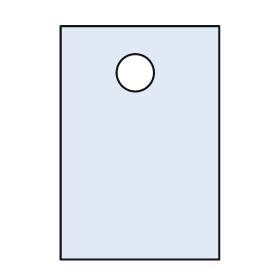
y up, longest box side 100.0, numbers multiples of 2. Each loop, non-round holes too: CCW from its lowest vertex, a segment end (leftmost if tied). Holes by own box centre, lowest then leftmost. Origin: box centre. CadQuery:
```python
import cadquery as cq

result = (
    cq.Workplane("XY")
    .moveTo(-34.0, -50.0)
    .lineTo(34.0, -50.0)
    .lineTo(34.0, 50.0)
    .lineTo(-34.0, 50.0)
    .close()
    .moveTo(-2.0, 30.0)
    .circle(8.0)
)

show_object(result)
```